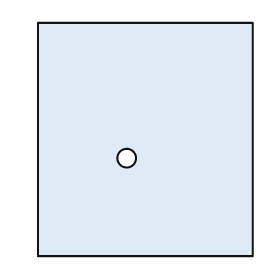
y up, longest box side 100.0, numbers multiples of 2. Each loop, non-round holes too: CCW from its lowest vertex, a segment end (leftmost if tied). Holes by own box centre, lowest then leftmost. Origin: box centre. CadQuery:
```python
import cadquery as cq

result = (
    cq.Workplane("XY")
    .moveTo(-46.0, -50.0)
    .lineTo(46.0, -50.0)
    .lineTo(46.0, 50.0)
    .lineTo(-46.0, 50.0)
    .close()
    .moveTo(-8.0, -8.0)
    .circle(4.0)
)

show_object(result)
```